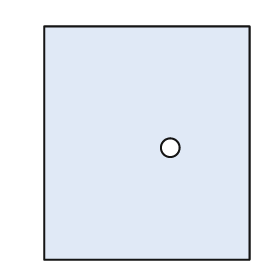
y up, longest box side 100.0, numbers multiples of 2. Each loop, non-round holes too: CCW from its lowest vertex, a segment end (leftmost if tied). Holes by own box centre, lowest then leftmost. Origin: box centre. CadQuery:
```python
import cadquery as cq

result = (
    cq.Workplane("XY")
    .moveTo(-44.0, -50.0)
    .lineTo(44.0, -50.0)
    .lineTo(44.0, 50.0)
    .lineTo(-44.0, 50.0)
    .close()
    .moveTo(10.0, -2.0)
    .circle(4.0)
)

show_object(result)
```